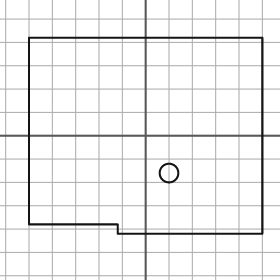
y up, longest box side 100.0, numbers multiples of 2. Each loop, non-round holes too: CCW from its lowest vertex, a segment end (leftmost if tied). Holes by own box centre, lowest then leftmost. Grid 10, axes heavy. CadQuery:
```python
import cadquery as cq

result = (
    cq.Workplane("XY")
    .moveTo(-12.0, -42.0)
    .lineTo(50.0, -42.0)
    .lineTo(50.0, 42.0)
    .lineTo(-50.0, 42.0)
    .lineTo(-50.0, -38.0)
    .lineTo(-12.0, -38.0)
    .close()
    .moveTo(10.0, -16.0)
    .circle(4.0)
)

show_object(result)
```